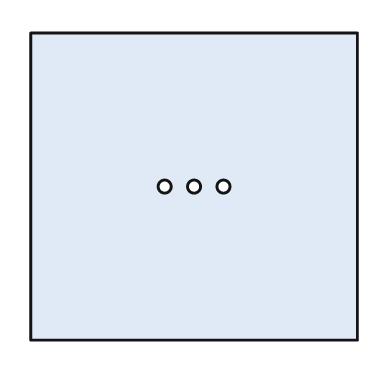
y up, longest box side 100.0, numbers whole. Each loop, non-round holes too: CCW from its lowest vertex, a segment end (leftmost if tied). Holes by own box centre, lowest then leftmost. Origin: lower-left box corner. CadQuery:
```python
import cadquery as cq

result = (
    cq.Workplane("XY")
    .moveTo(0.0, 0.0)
    .lineTo(100.0, 0.0)
    .lineTo(100.0, 94.0)
    .lineTo(0.0, 94.0)
    .close()
    .moveTo(41.0, 47.0)
    .circle(2.0)
    .moveTo(50.0, 47.0)
    .circle(2.0)
    .moveTo(59.0, 47.0)
    .circle(2.0)
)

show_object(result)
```